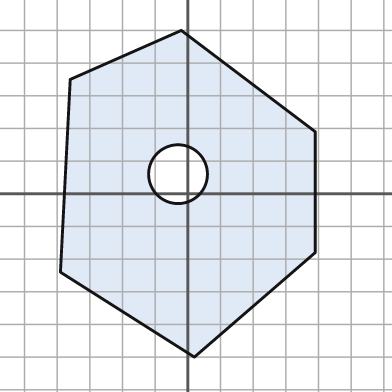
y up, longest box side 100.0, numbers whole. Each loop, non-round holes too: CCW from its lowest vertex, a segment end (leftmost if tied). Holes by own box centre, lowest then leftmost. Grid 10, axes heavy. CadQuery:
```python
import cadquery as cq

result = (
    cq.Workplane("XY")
    .moveTo(2.0, -50.0)
    .lineTo(39.0, -18.0)
    .lineTo(39.0, 19.0)
    .lineTo(-2.0, 50.0)
    .lineTo(-36.0, 35.0)
    .lineTo(-39.0, -24.0)
    .close()
    .moveTo(-3.0, 6.0)
    .circle(9.0)
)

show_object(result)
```